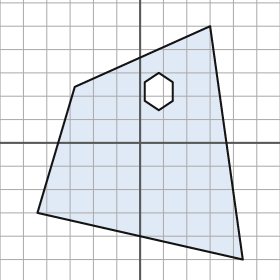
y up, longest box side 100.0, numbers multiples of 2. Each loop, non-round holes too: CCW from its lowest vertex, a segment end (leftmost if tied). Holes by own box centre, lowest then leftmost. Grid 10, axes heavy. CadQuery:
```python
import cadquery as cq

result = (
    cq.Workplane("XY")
    .moveTo(44.0, -50.0)
    .lineTo(30.0, 50.0)
    .lineTo(-28.0, 24.0)
    .lineTo(-44.0, -30.0)
    .close()
    .moveTo(8.0, 14.0)
    .lineTo(14.0, 18.0)
    .lineTo(14.0, 26.0)
    .lineTo(8.0, 30.0)
    .lineTo(2.0, 26.0)
    .lineTo(2.0, 18.0)
    .close()
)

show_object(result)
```